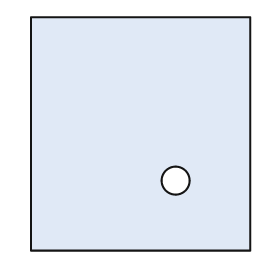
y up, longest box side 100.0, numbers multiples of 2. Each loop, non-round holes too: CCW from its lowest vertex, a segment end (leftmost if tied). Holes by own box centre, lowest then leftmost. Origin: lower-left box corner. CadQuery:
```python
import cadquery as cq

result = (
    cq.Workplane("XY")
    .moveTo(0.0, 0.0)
    .lineTo(94.0, 0.0)
    .lineTo(94.0, 100.0)
    .lineTo(0.0, 100.0)
    .close()
    .moveTo(62.0, 30.0)
    .circle(6.0)
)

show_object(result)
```